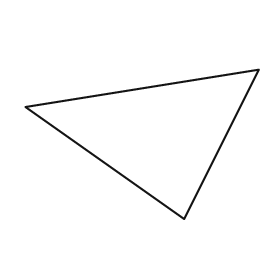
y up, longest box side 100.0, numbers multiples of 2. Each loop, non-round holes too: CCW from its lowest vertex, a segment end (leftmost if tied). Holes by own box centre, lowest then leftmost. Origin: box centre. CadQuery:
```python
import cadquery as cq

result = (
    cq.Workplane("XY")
    .moveTo(18.0, -32.0)
    .lineTo(50.0, 32.0)
    .lineTo(-50.0, 16.0)
    .close()
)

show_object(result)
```